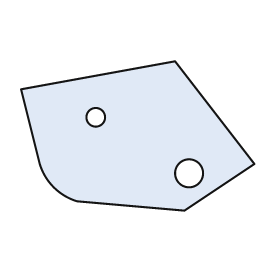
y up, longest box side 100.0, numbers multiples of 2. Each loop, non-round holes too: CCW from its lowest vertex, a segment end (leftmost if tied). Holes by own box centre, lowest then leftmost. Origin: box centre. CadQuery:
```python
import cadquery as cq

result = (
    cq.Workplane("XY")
    .moveTo(20.0, -32.0)
    .lineTo(50.0, -12.0)
    .lineTo(16.0, 32.0)
    .lineTo(-50.0, 20.0)
    .lineTo(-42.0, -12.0)
    .threePointArc((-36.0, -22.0), (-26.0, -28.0))
    .close()
    .moveTo(22.0, -16.0)
    .circle(6.0)
    .moveTo(-18.0, 8.0)
    .circle(4.0)
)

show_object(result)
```